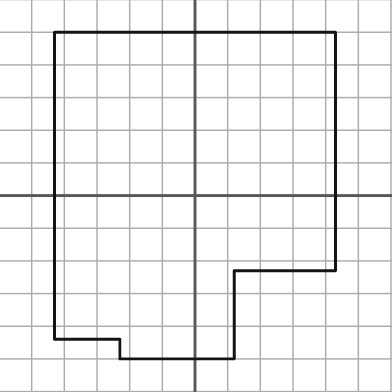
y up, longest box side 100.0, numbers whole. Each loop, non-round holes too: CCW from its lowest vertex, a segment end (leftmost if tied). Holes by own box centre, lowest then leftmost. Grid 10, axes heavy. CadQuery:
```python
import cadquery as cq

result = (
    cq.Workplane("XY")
    .moveTo(-23.0, -50.0)
    .lineTo(12.0, -50.0)
    .lineTo(12.0, -23.0)
    .lineTo(43.0, -23.0)
    .lineTo(43.0, 50.0)
    .lineTo(-43.0, 50.0)
    .lineTo(-43.0, -44.0)
    .lineTo(-23.0, -44.0)
    .close()
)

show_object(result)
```